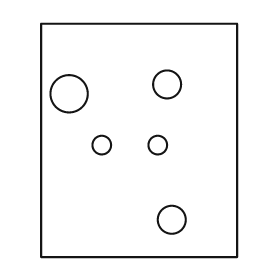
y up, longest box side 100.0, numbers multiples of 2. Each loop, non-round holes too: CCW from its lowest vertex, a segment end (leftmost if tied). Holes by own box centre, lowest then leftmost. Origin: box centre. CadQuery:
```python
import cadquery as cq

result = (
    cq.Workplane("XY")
    .moveTo(-42.0, -50.0)
    .lineTo(42.0, -50.0)
    .lineTo(42.0, 50.0)
    .lineTo(-42.0, 50.0)
    .close()
    .moveTo(14.0, -34.0)
    .circle(6.0)
    .moveTo(-16.0, -2.0)
    .circle(4.0)
    .moveTo(8.0, -2.0)
    .circle(4.0)
    .moveTo(-30.0, 20.0)
    .circle(8.0)
    .moveTo(12.0, 24.0)
    .circle(6.0)
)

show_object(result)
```